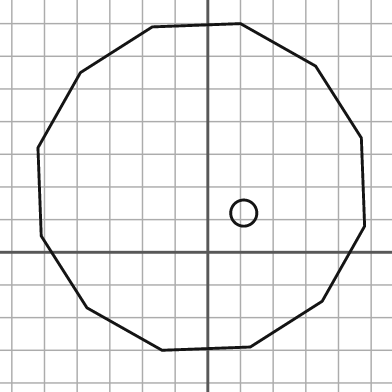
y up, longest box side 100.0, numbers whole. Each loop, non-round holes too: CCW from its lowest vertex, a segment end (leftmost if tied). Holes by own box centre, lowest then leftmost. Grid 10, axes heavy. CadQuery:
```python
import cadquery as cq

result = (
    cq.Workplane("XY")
    .moveTo(-14.0, -30.0)
    .lineTo(13.0, -29.0)
    .lineTo(35.0, -15.0)
    .lineTo(48.0, 8.0)
    .lineTo(47.0, 35.0)
    .lineTo(33.0, 57.0)
    .lineTo(10.0, 70.0)
    .lineTo(-17.0, 69.0)
    .lineTo(-39.0, 55.0)
    .lineTo(-52.0, 32.0)
    .lineTo(-51.0, 5.0)
    .lineTo(-37.0, -17.0)
    .close()
    .moveTo(11.0, 12.0)
    .circle(4.0)
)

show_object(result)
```